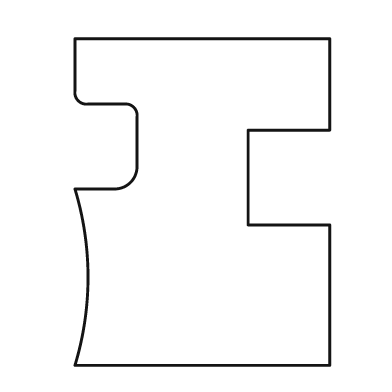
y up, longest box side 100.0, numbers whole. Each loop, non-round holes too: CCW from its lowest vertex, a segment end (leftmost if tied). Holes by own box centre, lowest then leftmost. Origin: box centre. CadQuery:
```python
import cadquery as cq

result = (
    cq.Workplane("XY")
    .moveTo(-39.0, -50.0)
    .lineTo(39.0, -50.0)
    .lineTo(39.0, -7.0)
    .lineTo(14.0, -7.0)
    .lineTo(14.0, 22.0)
    .lineTo(39.0, 22.0)
    .lineTo(39.0, 50.0)
    .lineTo(-39.0, 50.0)
    .lineTo(-39.0, 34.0)
    .threePointArc((-38.0, 31.0), (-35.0, 30.0))
    .lineTo(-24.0, 30.0)
    .threePointArc((-21.0, 29.0), (-20.0, 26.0))
    .lineTo(-20.0, 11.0)
    .threePointArc((-22.0, 6.0), (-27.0, 4.0))
    .lineTo(-39.0, 4.0)
    .threePointArc((-35.0, -23.0), (-39.0, -50.0))
    .close()
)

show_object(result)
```